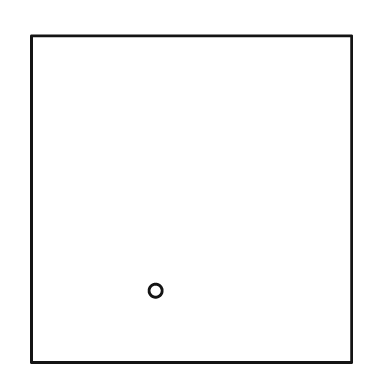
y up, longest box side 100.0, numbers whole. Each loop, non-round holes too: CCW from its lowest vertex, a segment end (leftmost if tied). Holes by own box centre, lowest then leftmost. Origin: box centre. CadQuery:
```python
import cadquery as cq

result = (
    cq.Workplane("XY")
    .moveTo(-49.0, -50.0)
    .lineTo(49.0, -50.0)
    .lineTo(49.0, 50.0)
    .lineTo(-49.0, 50.0)
    .close()
    .moveTo(-11.0, -28.0)
    .circle(2.0)
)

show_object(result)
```